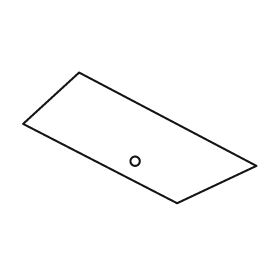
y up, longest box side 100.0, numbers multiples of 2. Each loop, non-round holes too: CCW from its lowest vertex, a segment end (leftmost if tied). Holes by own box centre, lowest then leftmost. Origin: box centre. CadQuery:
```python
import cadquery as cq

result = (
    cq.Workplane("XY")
    .moveTo(16.0, -28.0)
    .lineTo(50.0, -12.0)
    .lineTo(-26.0, 28.0)
    .lineTo(-50.0, 6.0)
    .close()
    .moveTo(-2.0, -10.0)
    .circle(2.0)
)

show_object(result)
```